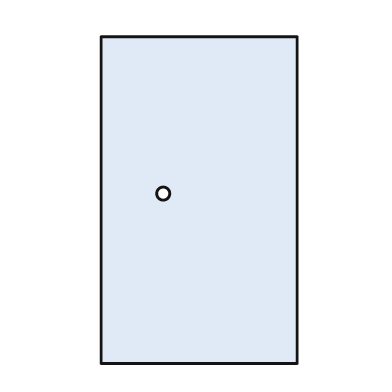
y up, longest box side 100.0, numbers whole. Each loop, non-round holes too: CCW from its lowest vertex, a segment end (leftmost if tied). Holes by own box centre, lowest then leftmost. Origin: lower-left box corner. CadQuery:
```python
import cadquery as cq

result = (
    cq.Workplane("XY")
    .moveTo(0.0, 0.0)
    .lineTo(60.0, 0.0)
    .lineTo(60.0, 100.0)
    .lineTo(0.0, 100.0)
    .close()
    .moveTo(19.0, 52.0)
    .circle(2.0)
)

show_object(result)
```